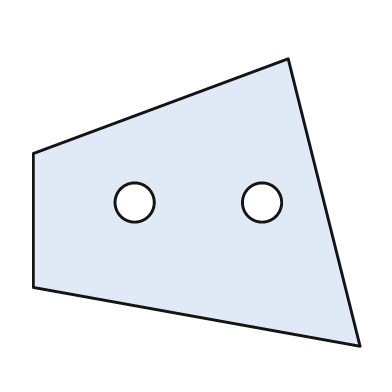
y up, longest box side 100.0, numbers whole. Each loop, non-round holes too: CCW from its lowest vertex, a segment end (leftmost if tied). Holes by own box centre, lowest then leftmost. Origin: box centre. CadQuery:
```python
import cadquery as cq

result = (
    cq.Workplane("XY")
    .moveTo(50.0, -44.0)
    .lineTo(28.0, 44.0)
    .lineTo(-50.0, 15.0)
    .lineTo(-50.0, -26.0)
    .close()
    .moveTo(-19.0, 0.0)
    .circle(6.0)
    .moveTo(20.0, 0.0)
    .circle(6.0)
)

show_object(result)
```